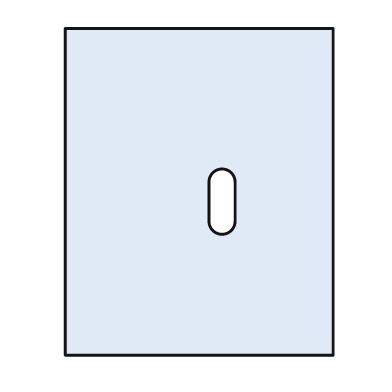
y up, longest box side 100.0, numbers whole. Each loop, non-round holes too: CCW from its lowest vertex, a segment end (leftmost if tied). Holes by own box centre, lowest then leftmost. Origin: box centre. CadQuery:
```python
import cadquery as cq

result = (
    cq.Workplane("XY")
    .moveTo(-41.0, -50.0)
    .lineTo(41.0, -50.0)
    .lineTo(41.0, 50.0)
    .lineTo(-41.0, 50.0)
    .close()
    .moveTo(3.0, -9.0)
    .threePointArc((7.0, -13.0), (11.0, -9.0))
    .lineTo(11.0, 3.0)
    .threePointArc((7.0, 7.0), (3.0, 3.0))
    .close()
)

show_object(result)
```